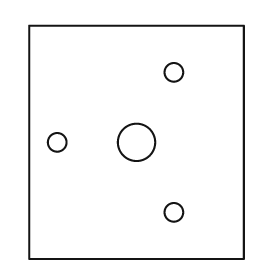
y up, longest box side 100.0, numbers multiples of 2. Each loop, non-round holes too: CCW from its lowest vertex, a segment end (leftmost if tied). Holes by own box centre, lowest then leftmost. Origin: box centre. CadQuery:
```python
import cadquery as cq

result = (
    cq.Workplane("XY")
    .moveTo(-46.0, -50.0)
    .lineTo(46.0, -50.0)
    .lineTo(46.0, 50.0)
    .lineTo(-46.0, 50.0)
    .close()
    .moveTo(16.0, -30.0)
    .circle(4.0)
    .moveTo(-34.0, 0.0)
    .circle(4.0)
    .moveTo(0.0, 0.0)
    .circle(8.0)
    .moveTo(16.0, 30.0)
    .circle(4.0)
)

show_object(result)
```